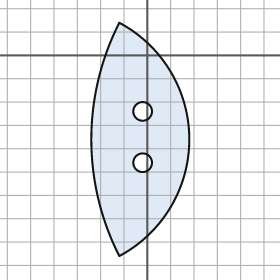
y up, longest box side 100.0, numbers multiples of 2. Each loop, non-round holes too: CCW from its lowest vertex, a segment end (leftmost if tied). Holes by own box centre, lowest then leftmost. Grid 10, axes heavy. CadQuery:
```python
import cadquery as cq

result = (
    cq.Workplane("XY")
    .moveTo(-12.0, -86.0)
    .threePointArc((18.0, -36.0), (-12.0, 14.0))
    .threePointArc((-24.0, -36.0), (-12.0, -86.0))
    .close()
    .moveTo(-2.0, -46.0)
    .circle(4.0)
    .moveTo(-2.0, -24.0)
    .circle(4.0)
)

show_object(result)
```